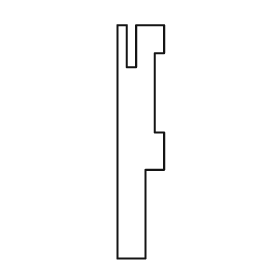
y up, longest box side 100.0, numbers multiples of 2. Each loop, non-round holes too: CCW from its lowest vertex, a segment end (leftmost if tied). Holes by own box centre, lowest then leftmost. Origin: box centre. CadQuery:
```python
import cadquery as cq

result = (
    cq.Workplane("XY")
    .moveTo(-10.0, -50.0)
    .lineTo(2.0, -50.0)
    .lineTo(2.0, -12.0)
    .lineTo(10.0, -12.0)
    .lineTo(10.0, 4.0)
    .lineTo(6.0, 4.0)
    .lineTo(6.0, 38.0)
    .lineTo(10.0, 38.0)
    .lineTo(10.0, 50.0)
    .lineTo(-2.0, 50.0)
    .lineTo(-2.0, 32.0)
    .lineTo(-6.0, 32.0)
    .lineTo(-6.0, 50.0)
    .lineTo(-10.0, 50.0)
    .close()
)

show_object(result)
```